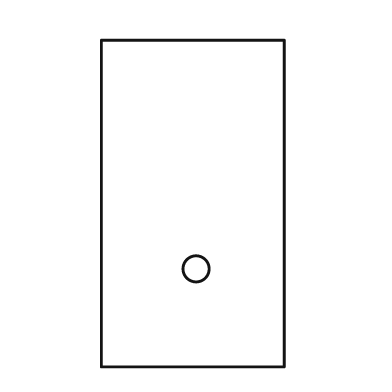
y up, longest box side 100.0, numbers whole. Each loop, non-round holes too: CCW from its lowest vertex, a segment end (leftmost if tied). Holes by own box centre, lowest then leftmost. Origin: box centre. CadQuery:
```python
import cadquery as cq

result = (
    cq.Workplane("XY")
    .moveTo(-28.0, -50.0)
    .lineTo(28.0, -50.0)
    .lineTo(28.0, 50.0)
    .lineTo(-28.0, 50.0)
    .close()
    .moveTo(1.0, -20.0)
    .circle(4.0)
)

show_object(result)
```